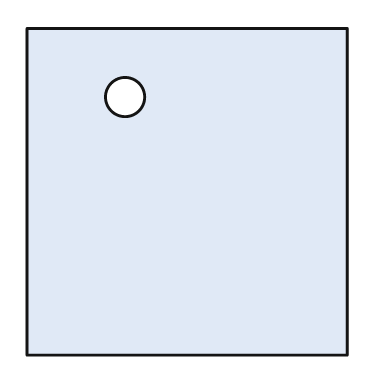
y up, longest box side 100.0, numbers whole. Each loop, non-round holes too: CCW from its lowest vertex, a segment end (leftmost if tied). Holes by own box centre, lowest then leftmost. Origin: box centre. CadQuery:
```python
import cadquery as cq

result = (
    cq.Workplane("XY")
    .moveTo(-49.0, -50.0)
    .lineTo(49.0, -50.0)
    .lineTo(49.0, 50.0)
    .lineTo(-49.0, 50.0)
    .close()
    .moveTo(-19.0, 29.0)
    .circle(6.0)
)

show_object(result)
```